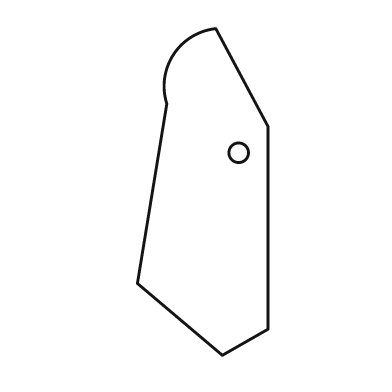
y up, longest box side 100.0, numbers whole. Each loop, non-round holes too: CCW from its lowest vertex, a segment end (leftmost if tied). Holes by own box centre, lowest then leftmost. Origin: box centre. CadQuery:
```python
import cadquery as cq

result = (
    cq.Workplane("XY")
    .moveTo(6.0, -50.0)
    .lineTo(20.0, -42.0)
    .lineTo(20.0, 20.0)
    .lineTo(4.0, 50.0)
    .threePointArc((-9.0, 42.0), (-11.0, 27.0))
    .lineTo(-20.0, -28.0)
    .close()
    .moveTo(11.0, 12.0)
    .circle(3.0)
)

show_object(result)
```